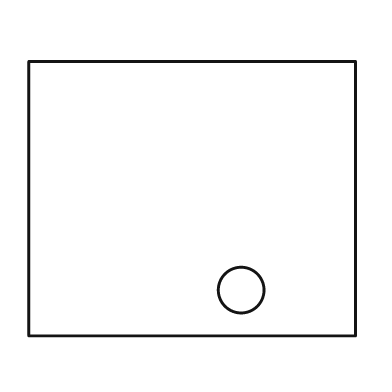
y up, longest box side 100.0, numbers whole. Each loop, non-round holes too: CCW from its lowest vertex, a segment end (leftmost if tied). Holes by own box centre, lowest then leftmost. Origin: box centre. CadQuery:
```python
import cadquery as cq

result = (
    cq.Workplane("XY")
    .moveTo(-50.0, -42.0)
    .lineTo(50.0, -42.0)
    .lineTo(50.0, 42.0)
    .lineTo(-50.0, 42.0)
    .close()
    .moveTo(15.0, -28.0)
    .circle(7.0)
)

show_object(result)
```